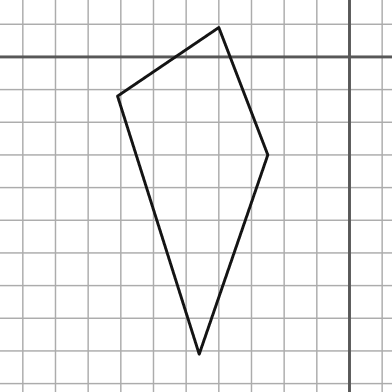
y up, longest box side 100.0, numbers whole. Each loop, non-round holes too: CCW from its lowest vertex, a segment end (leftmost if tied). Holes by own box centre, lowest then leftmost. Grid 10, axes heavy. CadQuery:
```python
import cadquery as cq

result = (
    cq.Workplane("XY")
    .moveTo(-46.0, -91.0)
    .lineTo(-25.0, -30.0)
    .lineTo(-40.0, 9.0)
    .lineTo(-71.0, -12.0)
    .close()
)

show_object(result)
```